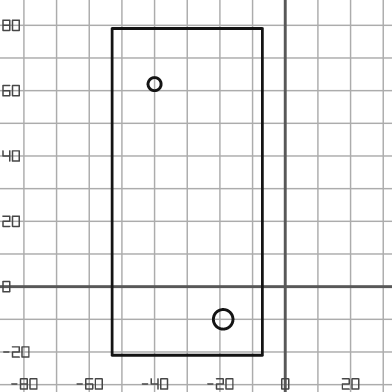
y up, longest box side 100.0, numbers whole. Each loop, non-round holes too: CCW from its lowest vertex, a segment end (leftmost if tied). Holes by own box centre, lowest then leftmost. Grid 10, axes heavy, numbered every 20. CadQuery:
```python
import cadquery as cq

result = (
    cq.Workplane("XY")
    .moveTo(-53.0, -21.0)
    .lineTo(-7.0, -21.0)
    .lineTo(-7.0, 79.0)
    .lineTo(-53.0, 79.0)
    .close()
    .moveTo(-19.0, -10.0)
    .circle(3.0)
    .moveTo(-40.0, 62.0)
    .circle(2.0)
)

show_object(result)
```